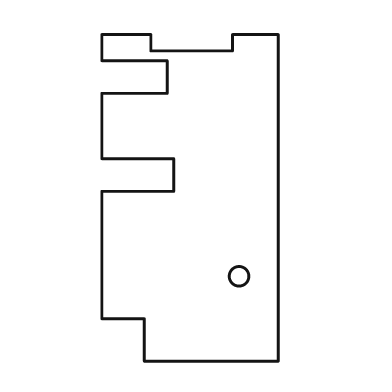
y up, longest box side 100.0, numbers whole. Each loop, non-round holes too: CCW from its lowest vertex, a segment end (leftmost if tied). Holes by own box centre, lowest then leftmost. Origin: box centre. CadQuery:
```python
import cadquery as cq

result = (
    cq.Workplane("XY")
    .moveTo(-14.0, -50.0)
    .lineTo(27.0, -50.0)
    .lineTo(27.0, 50.0)
    .lineTo(13.0, 50.0)
    .lineTo(13.0, 45.0)
    .lineTo(-12.0, 45.0)
    .lineTo(-12.0, 50.0)
    .lineTo(-27.0, 50.0)
    .lineTo(-27.0, 42.0)
    .lineTo(-7.0, 42.0)
    .lineTo(-7.0, 32.0)
    .lineTo(-27.0, 32.0)
    .lineTo(-27.0, 12.0)
    .lineTo(-5.0, 12.0)
    .lineTo(-5.0, 2.0)
    .lineTo(-27.0, 2.0)
    .lineTo(-27.0, -37.0)
    .lineTo(-14.0, -37.0)
    .close()
    .moveTo(15.0, -24.0)
    .circle(3.0)
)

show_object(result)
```